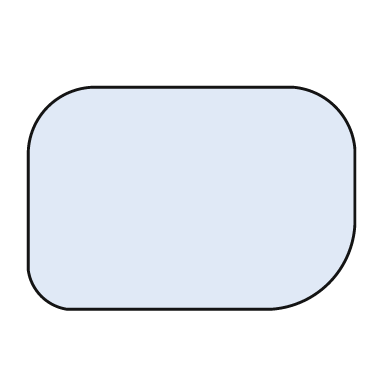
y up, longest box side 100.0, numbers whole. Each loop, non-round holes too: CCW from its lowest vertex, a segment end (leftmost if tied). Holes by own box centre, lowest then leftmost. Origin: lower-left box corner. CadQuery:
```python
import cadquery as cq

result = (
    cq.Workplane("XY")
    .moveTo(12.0, 0.0)
    .lineTo(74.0, 0.0)
    .threePointArc((92.0, 8.0), (100.0, 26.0))
    .lineTo(100.0, 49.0)
    .threePointArc((94.0, 62.0), (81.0, 68.0))
    .lineTo(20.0, 68.0)
    .threePointArc((6.0, 62.0), (0.0, 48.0))
    .lineTo(0.0, 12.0)
    .threePointArc((4.0, 4.0), (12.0, 0.0))
    .close()
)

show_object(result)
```